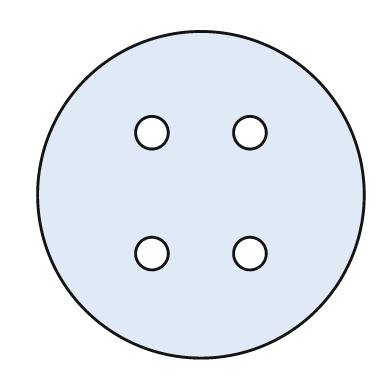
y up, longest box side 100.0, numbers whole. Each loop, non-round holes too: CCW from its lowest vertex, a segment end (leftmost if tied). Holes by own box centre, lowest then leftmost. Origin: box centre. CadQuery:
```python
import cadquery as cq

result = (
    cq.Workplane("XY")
    .moveTo(0.0, 0.0)
    .circle(50.0)
    .moveTo(-15.0, -18.0)
    .circle(5.0)
    .moveTo(15.0, -18.0)
    .circle(5.0)
    .moveTo(-15.0, 19.0)
    .circle(5.0)
    .moveTo(15.0, 19.0)
    .circle(5.0)
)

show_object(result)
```